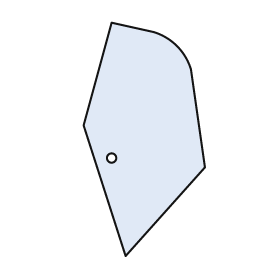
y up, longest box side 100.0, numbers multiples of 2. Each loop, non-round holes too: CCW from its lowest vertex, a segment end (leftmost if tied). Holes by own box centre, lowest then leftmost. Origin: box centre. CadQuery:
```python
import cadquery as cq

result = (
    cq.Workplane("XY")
    .moveTo(-8.0, -50.0)
    .lineTo(26.0, -12.0)
    .lineTo(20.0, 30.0)
    .threePointArc((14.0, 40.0), (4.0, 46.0))
    .lineTo(-14.0, 50.0)
    .lineTo(-26.0, 6.0)
    .close()
    .moveTo(-14.0, -8.0)
    .circle(2.0)
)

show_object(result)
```